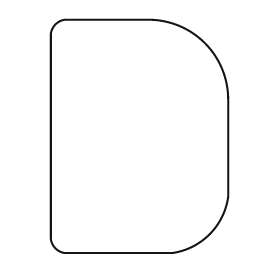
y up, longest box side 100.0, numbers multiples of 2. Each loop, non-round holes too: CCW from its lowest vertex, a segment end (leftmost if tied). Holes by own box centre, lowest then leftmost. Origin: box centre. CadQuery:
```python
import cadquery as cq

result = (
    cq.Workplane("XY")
    .moveTo(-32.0, -50.0)
    .lineTo(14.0, -50.0)
    .threePointArc((30.0, -42.0), (38.0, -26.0))
    .lineTo(38.0, 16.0)
    .threePointArc((28.0, 40.0), (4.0, 50.0))
    .lineTo(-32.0, 50.0)
    .threePointArc((-36.0, 48.0), (-38.0, 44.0))
    .lineTo(-38.0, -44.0)
    .threePointArc((-36.0, -48.0), (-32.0, -50.0))
    .close()
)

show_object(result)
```